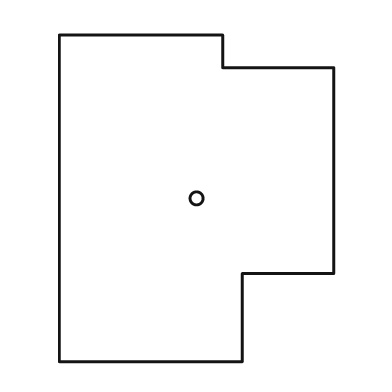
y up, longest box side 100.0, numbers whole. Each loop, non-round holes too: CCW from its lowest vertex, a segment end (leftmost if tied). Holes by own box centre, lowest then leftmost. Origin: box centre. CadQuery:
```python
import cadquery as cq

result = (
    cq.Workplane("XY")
    .moveTo(-42.0, -50.0)
    .lineTo(14.0, -50.0)
    .lineTo(14.0, -23.0)
    .lineTo(42.0, -23.0)
    .lineTo(42.0, 40.0)
    .lineTo(8.0, 40.0)
    .lineTo(8.0, 50.0)
    .lineTo(-42.0, 50.0)
    .close()
    .moveTo(0.0, 0.0)
    .circle(2.0)
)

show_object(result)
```